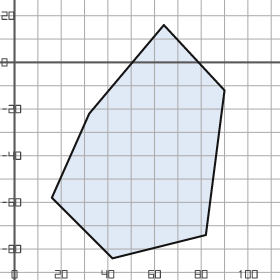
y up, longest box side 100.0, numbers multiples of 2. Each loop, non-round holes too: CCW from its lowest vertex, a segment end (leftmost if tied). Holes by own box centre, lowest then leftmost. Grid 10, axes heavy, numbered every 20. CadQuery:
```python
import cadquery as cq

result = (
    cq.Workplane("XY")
    .moveTo(42.0, -84.0)
    .lineTo(82.0, -74.0)
    .lineTo(90.0, -12.0)
    .lineTo(64.0, 16.0)
    .lineTo(32.0, -22.0)
    .lineTo(16.0, -58.0)
    .close()
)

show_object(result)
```